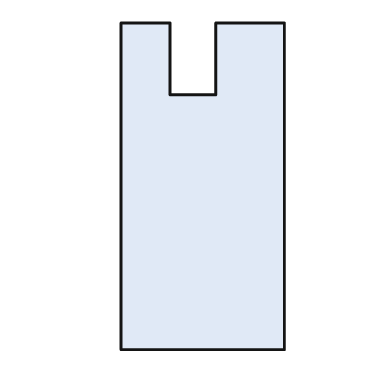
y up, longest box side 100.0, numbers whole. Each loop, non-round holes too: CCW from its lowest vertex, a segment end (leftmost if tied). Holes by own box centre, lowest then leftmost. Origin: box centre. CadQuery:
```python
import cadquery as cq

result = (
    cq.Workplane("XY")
    .moveTo(-25.0, -50.0)
    .lineTo(25.0, -50.0)
    .lineTo(25.0, 50.0)
    .lineTo(4.0, 50.0)
    .lineTo(4.0, 28.0)
    .lineTo(-10.0, 28.0)
    .lineTo(-10.0, 50.0)
    .lineTo(-25.0, 50.0)
    .close()
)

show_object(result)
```